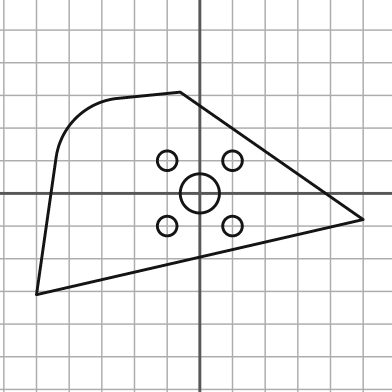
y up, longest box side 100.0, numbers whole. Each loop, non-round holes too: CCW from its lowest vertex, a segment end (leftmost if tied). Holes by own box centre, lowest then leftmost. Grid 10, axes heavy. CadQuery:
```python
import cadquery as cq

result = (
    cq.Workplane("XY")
    .moveTo(-50.0, -31.0)
    .lineTo(50.0, -8.0)
    .lineTo(-6.0, 31.0)
    .lineTo(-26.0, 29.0)
    .threePointArc((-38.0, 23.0), (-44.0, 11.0))
    .close()
    .moveTo(-10.0, -10.0)
    .circle(3.0)
    .moveTo(10.0, -10.0)
    .circle(3.0)
    .moveTo(0.0, 0.0)
    .circle(6.0)
    .moveTo(-10.0, 10.0)
    .circle(3.0)
    .moveTo(10.0, 10.0)
    .circle(3.0)
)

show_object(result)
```